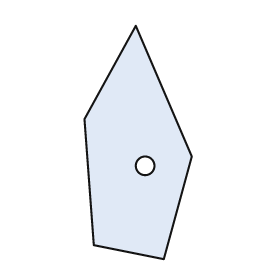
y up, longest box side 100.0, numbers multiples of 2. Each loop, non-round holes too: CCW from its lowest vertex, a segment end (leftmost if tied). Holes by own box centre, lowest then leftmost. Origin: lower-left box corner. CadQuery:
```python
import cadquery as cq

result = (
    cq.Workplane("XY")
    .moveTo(34.0, 0.0)
    .lineTo(46.0, 44.0)
    .lineTo(22.0, 100.0)
    .lineTo(0.0, 60.0)
    .lineTo(4.0, 6.0)
    .close()
    .moveTo(26.0, 40.0)
    .circle(4.0)
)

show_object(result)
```